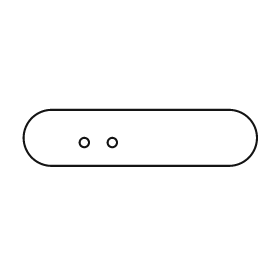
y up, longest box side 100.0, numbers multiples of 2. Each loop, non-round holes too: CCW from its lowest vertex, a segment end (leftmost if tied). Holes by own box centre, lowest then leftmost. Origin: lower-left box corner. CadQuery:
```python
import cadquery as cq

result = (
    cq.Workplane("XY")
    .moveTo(12.0, 0.0)
    .lineTo(88.0, 0.0)
    .threePointArc((100.0, 12.0), (88.0, 24.0))
    .lineTo(12.0, 24.0)
    .threePointArc((0.0, 12.0), (12.0, 0.0))
    .close()
    .moveTo(26.0, 10.0)
    .circle(2.0)
    .moveTo(38.0, 10.0)
    .circle(2.0)
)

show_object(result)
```